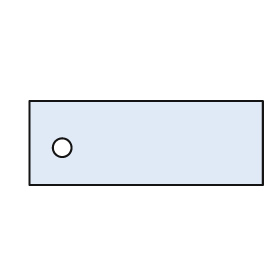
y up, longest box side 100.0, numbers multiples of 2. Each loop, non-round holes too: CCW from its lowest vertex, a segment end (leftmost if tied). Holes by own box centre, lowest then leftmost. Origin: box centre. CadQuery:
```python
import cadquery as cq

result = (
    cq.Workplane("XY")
    .moveTo(-50.0, -18.0)
    .lineTo(50.0, -18.0)
    .lineTo(50.0, 18.0)
    .lineTo(-50.0, 18.0)
    .close()
    .moveTo(-36.0, -2.0)
    .circle(4.0)
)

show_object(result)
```